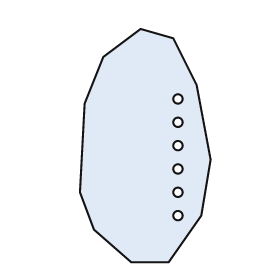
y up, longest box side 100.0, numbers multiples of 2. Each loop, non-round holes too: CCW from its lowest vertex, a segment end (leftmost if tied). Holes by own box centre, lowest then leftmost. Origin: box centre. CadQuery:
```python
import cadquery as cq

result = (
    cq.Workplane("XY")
    .moveTo(-6.0, -50.0)
    .lineTo(10.0, -50.0)
    .lineTo(24.0, -30.0)
    .lineTo(28.0, -6.0)
    .lineTo(22.0, 26.0)
    .lineTo(12.0, 46.0)
    .lineTo(-2.0, 50.0)
    .lineTo(-18.0, 38.0)
    .lineTo(-26.0, 18.0)
    .lineTo(-28.0, -20.0)
    .lineTo(-22.0, -36.0)
    .close()
    .moveTo(14.0, -30.0)
    .circle(2.0)
    .moveTo(14.0, -20.0)
    .circle(2.0)
    .moveTo(14.0, -10.0)
    .circle(2.0)
    .moveTo(14.0, 0.0)
    .circle(2.0)
    .moveTo(14.0, 10.0)
    .circle(2.0)
    .moveTo(14.0, 20.0)
    .circle(2.0)
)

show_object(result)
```